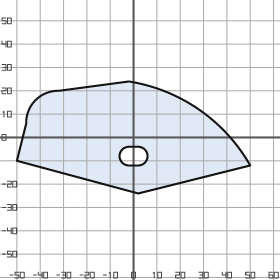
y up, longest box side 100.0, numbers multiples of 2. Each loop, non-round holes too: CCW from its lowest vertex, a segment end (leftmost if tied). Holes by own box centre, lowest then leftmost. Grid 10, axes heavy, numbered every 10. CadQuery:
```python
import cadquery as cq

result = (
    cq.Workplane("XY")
    .moveTo(2.0, -24.0)
    .lineTo(50.0, -12.0)
    .threePointArc((28.0, 12.0), (-2.0, 24.0))
    .lineTo(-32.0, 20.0)
    .threePointArc((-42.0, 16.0), (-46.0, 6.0))
    .lineTo(-50.0, -10.0)
    .close()
    .moveTo(-2.0, -12.0)
    .lineTo(2.0, -12.0)
    .threePointArc((6.0, -8.0), (2.0, -4.0))
    .lineTo(-2.0, -4.0)
    .threePointArc((-6.0, -8.0), (-2.0, -12.0))
    .close()
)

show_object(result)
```